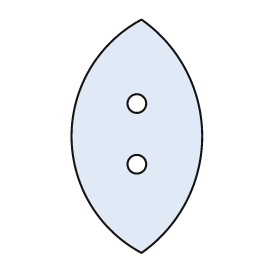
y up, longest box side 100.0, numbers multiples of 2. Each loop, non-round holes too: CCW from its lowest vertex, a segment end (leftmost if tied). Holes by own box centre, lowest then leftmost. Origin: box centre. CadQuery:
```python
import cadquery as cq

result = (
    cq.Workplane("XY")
    .moveTo(2.0, -50.0)
    .threePointArc((28.0, 0.0), (2.0, 50.0))
    .threePointArc((-28.0, 0.0), (2.0, -50.0))
    .close()
    .moveTo(0.0, -12.0)
    .circle(4.0)
    .moveTo(0.0, 14.0)
    .circle(4.0)
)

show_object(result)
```